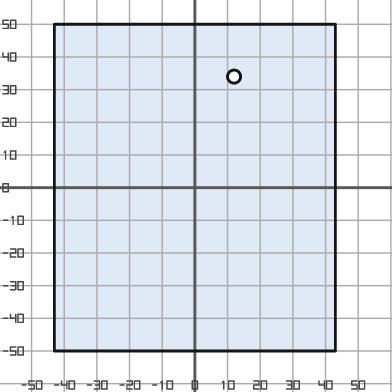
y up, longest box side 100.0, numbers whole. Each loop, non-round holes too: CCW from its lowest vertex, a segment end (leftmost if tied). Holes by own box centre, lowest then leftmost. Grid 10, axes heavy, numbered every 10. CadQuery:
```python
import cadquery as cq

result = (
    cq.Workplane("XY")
    .moveTo(-43.0, -50.0)
    .lineTo(43.0, -50.0)
    .lineTo(43.0, 50.0)
    .lineTo(-43.0, 50.0)
    .close()
    .moveTo(12.0, 34.0)
    .circle(2.0)
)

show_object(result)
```